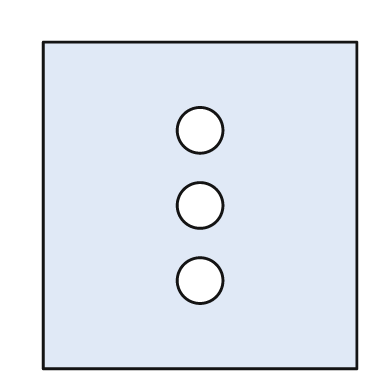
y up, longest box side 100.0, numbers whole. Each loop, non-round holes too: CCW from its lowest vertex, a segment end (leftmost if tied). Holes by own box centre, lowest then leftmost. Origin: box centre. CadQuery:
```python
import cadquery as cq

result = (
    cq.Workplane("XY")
    .moveTo(-48.0, -50.0)
    .lineTo(48.0, -50.0)
    .lineTo(48.0, 50.0)
    .lineTo(-48.0, 50.0)
    .close()
    .moveTo(0.0, -23.0)
    .circle(7.0)
    .moveTo(0.0, 0.0)
    .circle(7.0)
    .moveTo(0.0, 23.0)
    .circle(7.0)
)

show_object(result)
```